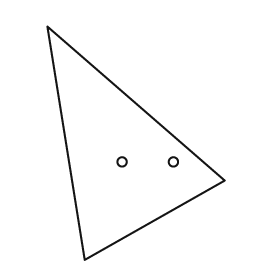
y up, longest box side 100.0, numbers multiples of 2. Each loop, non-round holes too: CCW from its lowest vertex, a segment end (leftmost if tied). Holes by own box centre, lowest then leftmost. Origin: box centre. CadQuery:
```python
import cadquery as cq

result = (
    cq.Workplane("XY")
    .moveTo(-22.0, -50.0)
    .lineTo(38.0, -16.0)
    .lineTo(-38.0, 50.0)
    .close()
    .moveTo(-6.0, -8.0)
    .circle(2.0)
    .moveTo(16.0, -8.0)
    .circle(2.0)
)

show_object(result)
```